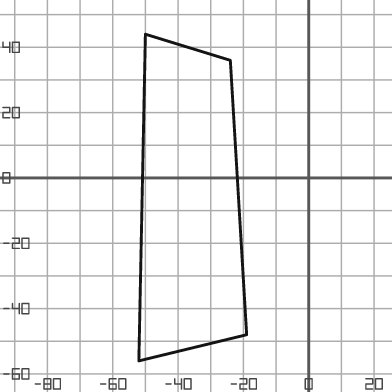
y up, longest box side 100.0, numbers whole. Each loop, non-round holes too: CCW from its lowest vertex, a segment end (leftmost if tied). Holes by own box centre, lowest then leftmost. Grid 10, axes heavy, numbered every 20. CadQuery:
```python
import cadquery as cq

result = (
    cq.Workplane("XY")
    .moveTo(-52.0, -56.0)
    .lineTo(-19.0, -48.0)
    .lineTo(-24.0, 36.0)
    .lineTo(-50.0, 44.0)
    .close()
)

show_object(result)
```